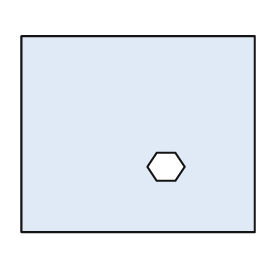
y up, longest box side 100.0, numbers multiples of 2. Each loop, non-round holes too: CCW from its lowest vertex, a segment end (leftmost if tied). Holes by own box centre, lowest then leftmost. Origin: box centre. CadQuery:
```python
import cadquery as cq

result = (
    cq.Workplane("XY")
    .moveTo(-50.0, -42.0)
    .lineTo(50.0, -42.0)
    .lineTo(50.0, 42.0)
    .lineTo(-50.0, 42.0)
    .close()
    .moveTo(8.0, -20.0)
    .lineTo(16.0, -20.0)
    .lineTo(20.0, -14.0)
    .lineTo(16.0, -8.0)
    .lineTo(8.0, -8.0)
    .lineTo(4.0, -14.0)
    .close()
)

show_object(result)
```